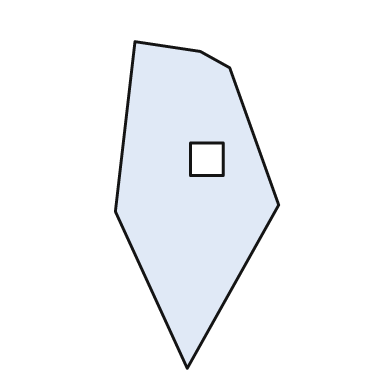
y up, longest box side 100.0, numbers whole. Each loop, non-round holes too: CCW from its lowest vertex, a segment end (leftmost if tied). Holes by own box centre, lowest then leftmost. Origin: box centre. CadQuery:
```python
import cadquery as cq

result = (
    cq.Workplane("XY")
    .moveTo(-3.0, -50.0)
    .lineTo(25.0, 0.0)
    .lineTo(10.0, 42.0)
    .lineTo(1.0, 47.0)
    .lineTo(-19.0, 50.0)
    .lineTo(-25.0, -2.0)
    .close()
    .moveTo(-2.0, 9.0)
    .lineTo(8.0, 9.0)
    .lineTo(8.0, 19.0)
    .lineTo(-2.0, 19.0)
    .close()
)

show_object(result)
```